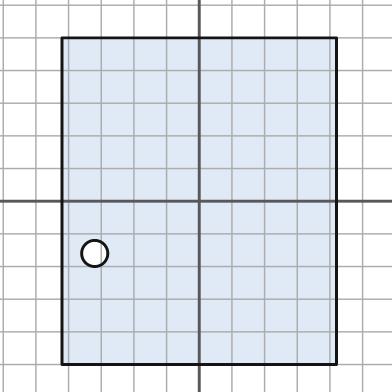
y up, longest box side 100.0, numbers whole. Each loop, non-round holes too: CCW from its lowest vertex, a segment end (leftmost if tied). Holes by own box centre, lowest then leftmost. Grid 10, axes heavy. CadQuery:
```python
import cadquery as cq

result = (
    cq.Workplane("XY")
    .moveTo(-42.0, -50.0)
    .lineTo(42.0, -50.0)
    .lineTo(42.0, 50.0)
    .lineTo(-42.0, 50.0)
    .close()
    .moveTo(-32.0, -16.0)
    .circle(4.0)
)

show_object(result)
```